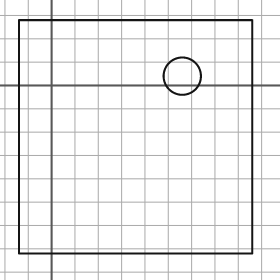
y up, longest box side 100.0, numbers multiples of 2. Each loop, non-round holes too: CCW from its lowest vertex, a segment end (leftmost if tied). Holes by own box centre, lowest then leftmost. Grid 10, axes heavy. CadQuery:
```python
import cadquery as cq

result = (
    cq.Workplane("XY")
    .moveTo(-14.0, -72.0)
    .lineTo(86.0, -72.0)
    .lineTo(86.0, 28.0)
    .lineTo(-14.0, 28.0)
    .close()
    .moveTo(56.0, 4.0)
    .circle(8.0)
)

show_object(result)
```